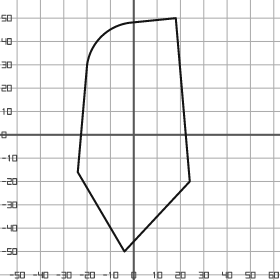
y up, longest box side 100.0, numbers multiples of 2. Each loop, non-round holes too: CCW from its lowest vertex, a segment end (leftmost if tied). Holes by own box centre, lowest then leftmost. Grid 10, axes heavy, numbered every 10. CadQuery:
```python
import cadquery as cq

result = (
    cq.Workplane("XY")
    .moveTo(-4.0, -50.0)
    .lineTo(24.0, -20.0)
    .lineTo(18.0, 50.0)
    .lineTo(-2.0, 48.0)
    .threePointArc((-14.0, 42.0), (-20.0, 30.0))
    .lineTo(-24.0, -16.0)
    .close()
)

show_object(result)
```